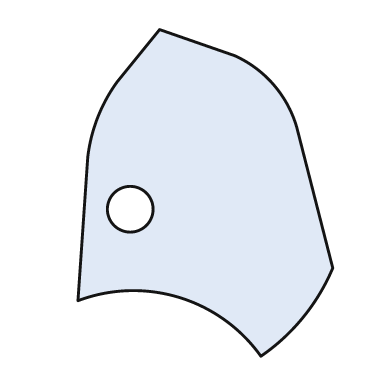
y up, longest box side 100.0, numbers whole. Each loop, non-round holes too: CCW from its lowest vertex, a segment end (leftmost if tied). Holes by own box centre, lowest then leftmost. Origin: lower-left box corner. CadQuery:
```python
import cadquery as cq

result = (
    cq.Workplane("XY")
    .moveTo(56.0, 0.0)
    .threePointArc((69.0, 12.0), (78.0, 27.0))
    .lineTo(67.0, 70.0)
    .threePointArc((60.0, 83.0), (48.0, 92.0))
    .lineTo(25.0, 100.0)
    .lineTo(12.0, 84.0)
    .threePointArc((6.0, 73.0), (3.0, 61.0))
    .lineTo(0.0, 17.0)
    .threePointArc((31.0, 18.0), (56.0, 0.0))
    .close()
    .moveTo(16.0, 45.0)
    .circle(7.0)
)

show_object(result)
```